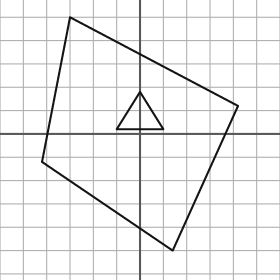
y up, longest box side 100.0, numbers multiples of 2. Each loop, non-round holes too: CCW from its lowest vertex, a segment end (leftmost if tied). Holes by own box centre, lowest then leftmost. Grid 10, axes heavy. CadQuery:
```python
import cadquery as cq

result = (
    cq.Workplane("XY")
    .moveTo(14.0, -50.0)
    .lineTo(42.0, 12.0)
    .lineTo(-30.0, 50.0)
    .lineTo(-42.0, -12.0)
    .close()
    .moveTo(-10.0, 2.0)
    .lineTo(10.0, 2.0)
    .lineTo(0.0, 18.0)
    .close()
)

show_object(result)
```